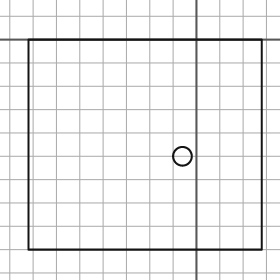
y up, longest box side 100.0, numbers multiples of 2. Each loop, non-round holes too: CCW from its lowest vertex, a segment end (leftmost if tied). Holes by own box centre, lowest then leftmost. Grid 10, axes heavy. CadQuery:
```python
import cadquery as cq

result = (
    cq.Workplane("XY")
    .moveTo(-72.0, -90.0)
    .lineTo(28.0, -90.0)
    .lineTo(28.0, 0.0)
    .lineTo(-72.0, 0.0)
    .close()
    .moveTo(-6.0, -50.0)
    .circle(4.0)
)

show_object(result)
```